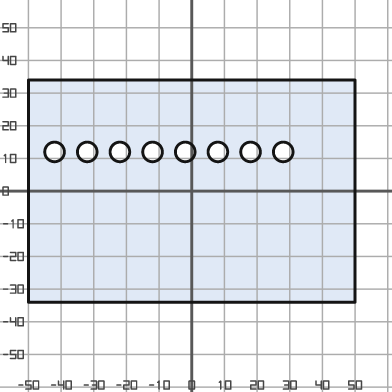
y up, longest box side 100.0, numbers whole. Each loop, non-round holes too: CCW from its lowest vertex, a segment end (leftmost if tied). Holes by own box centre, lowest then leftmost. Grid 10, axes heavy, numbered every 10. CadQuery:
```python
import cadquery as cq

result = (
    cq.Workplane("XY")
    .moveTo(-50.0, -34.0)
    .lineTo(50.0, -34.0)
    .lineTo(50.0, 34.0)
    .lineTo(-50.0, 34.0)
    .close()
    .moveTo(-42.0, 12.0)
    .circle(3.0)
    .moveTo(-32.0, 12.0)
    .circle(3.0)
    .moveTo(-22.0, 12.0)
    .circle(3.0)
    .moveTo(-12.0, 12.0)
    .circle(3.0)
    .moveTo(-2.0, 12.0)
    .circle(3.0)
    .moveTo(8.0, 12.0)
    .circle(3.0)
    .moveTo(18.0, 12.0)
    .circle(3.0)
    .moveTo(28.0, 12.0)
    .circle(3.0)
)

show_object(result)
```